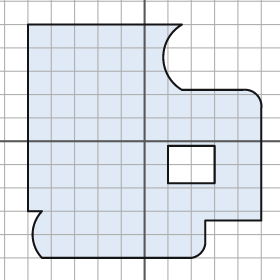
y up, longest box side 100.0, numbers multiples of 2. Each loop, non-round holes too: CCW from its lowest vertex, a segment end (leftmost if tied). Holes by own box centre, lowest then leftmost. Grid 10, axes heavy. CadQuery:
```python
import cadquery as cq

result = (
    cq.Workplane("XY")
    .moveTo(-44.0, -50.0)
    .lineTo(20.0, -50.0)
    .threePointArc((24.0, -48.0), (26.0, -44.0))
    .lineTo(26.0, -34.0)
    .lineTo(50.0, -34.0)
    .lineTo(50.0, 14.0)
    .threePointArc((48.0, 20.0), (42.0, 22.0))
    .lineTo(16.0, 22.0)
    .threePointArc((8.0, 36.0), (16.0, 50.0))
    .lineTo(-50.0, 50.0)
    .lineTo(-50.0, -30.0)
    .lineTo(-44.0, -30.0)
    .threePointArc((-48.0, -40.0), (-44.0, -50.0))
    .close()
    .moveTo(10.0, -18.0)
    .lineTo(30.0, -18.0)
    .lineTo(30.0, -2.0)
    .lineTo(10.0, -2.0)
    .close()
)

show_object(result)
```